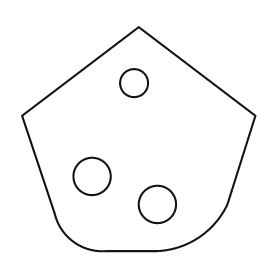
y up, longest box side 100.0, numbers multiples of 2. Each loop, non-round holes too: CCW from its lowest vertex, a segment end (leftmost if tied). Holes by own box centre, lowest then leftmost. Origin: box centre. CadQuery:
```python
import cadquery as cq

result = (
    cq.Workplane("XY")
    .moveTo(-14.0, -48.0)
    .lineTo(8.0, -48.0)
    .threePointArc((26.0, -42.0), (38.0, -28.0))
    .lineTo(50.0, 10.0)
    .lineTo(0.0, 48.0)
    .lineTo(-50.0, 10.0)
    .lineTo(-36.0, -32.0)
    .threePointArc((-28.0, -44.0), (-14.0, -48.0))
    .close()
    .moveTo(8.0, -28.0)
    .circle(8.0)
    .moveTo(-20.0, -16.0)
    .circle(8.0)
    .moveTo(-2.0, 24.0)
    .circle(6.0)
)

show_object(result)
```